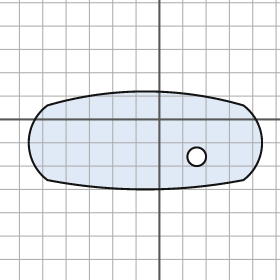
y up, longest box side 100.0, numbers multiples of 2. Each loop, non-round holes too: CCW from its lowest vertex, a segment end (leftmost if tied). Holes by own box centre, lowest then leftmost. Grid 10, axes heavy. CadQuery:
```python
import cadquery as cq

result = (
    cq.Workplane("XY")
    .moveTo(-48.0, -26.0)
    .threePointArc((-6.0, -30.0), (36.0, -26.0))
    .threePointArc((44.0, -10.0), (36.0, 6.0))
    .threePointArc((-6.0, 12.0), (-48.0, 6.0))
    .threePointArc((-56.0, -10.0), (-48.0, -26.0))
    .close()
    .moveTo(16.0, -16.0)
    .circle(4.0)
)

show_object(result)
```